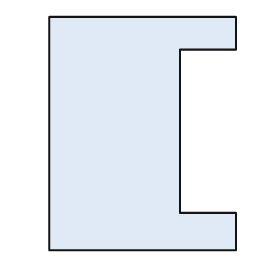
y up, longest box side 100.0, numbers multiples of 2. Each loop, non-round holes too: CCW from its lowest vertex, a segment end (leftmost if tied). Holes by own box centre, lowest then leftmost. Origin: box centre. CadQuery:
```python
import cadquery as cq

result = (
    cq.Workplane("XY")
    .moveTo(-40.0, -50.0)
    .lineTo(40.0, -50.0)
    .lineTo(40.0, -34.0)
    .lineTo(16.0, -34.0)
    .lineTo(16.0, 36.0)
    .lineTo(40.0, 36.0)
    .lineTo(40.0, 50.0)
    .lineTo(-40.0, 50.0)
    .close()
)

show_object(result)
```